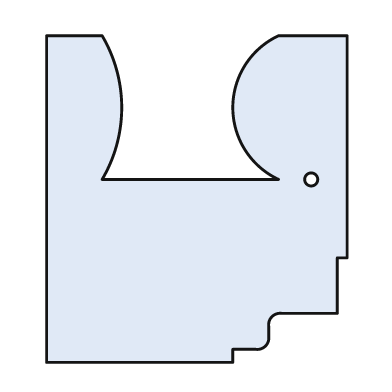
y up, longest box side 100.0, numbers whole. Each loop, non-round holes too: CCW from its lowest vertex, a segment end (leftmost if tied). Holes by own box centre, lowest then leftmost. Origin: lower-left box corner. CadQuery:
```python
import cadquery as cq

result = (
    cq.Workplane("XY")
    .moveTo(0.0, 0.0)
    .lineTo(57.0, 0.0)
    .lineTo(57.0, 4.0)
    .lineTo(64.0, 4.0)
    .threePointArc((67.0, 5.0), (68.0, 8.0))
    .lineTo(68.0, 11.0)
    .threePointArc((69.0, 14.0), (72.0, 15.0))
    .lineTo(89.0, 15.0)
    .lineTo(89.0, 32.0)
    .lineTo(92.0, 32.0)
    .lineTo(92.0, 100.0)
    .lineTo(71.0, 100.0)
    .threePointArc((57.0, 78.0), (71.0, 56.0))
    .lineTo(17.0, 56.0)
    .threePointArc((23.0, 78.0), (17.0, 100.0))
    .lineTo(0.0, 100.0)
    .close()
    .moveTo(81.0, 56.0)
    .circle(2.0)
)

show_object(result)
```